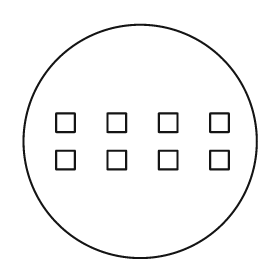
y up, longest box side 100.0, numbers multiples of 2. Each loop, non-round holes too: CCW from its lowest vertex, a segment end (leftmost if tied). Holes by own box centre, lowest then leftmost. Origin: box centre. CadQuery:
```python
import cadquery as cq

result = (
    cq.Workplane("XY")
    .moveTo(0.0, 0.0)
    .circle(50.0)
    .moveTo(-36.0, -12.0)
    .lineTo(-28.0, -12.0)
    .lineTo(-28.0, -4.0)
    .lineTo(-36.0, -4.0)
    .close()
    .moveTo(-14.0, -12.0)
    .lineTo(-6.0, -12.0)
    .lineTo(-6.0, -4.0)
    .lineTo(-14.0, -4.0)
    .close()
    .moveTo(8.0, -12.0)
    .lineTo(16.0, -12.0)
    .lineTo(16.0, -4.0)
    .lineTo(8.0, -4.0)
    .close()
    .moveTo(30.0, -12.0)
    .lineTo(38.0, -12.0)
    .lineTo(38.0, -4.0)
    .lineTo(30.0, -4.0)
    .close()
    .moveTo(-36.0, 4.0)
    .lineTo(-28.0, 4.0)
    .lineTo(-28.0, 12.0)
    .lineTo(-36.0, 12.0)
    .close()
    .moveTo(-14.0, 4.0)
    .lineTo(-6.0, 4.0)
    .lineTo(-6.0, 12.0)
    .lineTo(-14.0, 12.0)
    .close()
    .moveTo(8.0, 4.0)
    .lineTo(16.0, 4.0)
    .lineTo(16.0, 12.0)
    .lineTo(8.0, 12.0)
    .close()
    .moveTo(30.0, 4.0)
    .lineTo(38.0, 4.0)
    .lineTo(38.0, 12.0)
    .lineTo(30.0, 12.0)
    .close()
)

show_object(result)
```